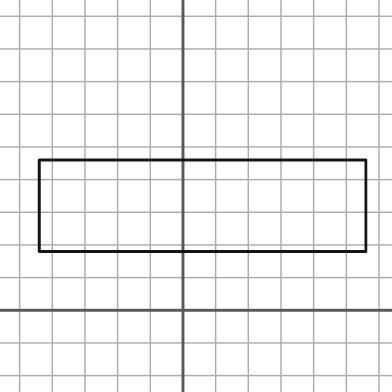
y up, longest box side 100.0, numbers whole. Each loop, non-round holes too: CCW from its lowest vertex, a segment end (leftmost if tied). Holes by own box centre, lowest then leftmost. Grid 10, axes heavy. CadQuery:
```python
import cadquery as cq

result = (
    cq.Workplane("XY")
    .moveTo(-44.0, 18.0)
    .lineTo(56.0, 18.0)
    .lineTo(56.0, 46.0)
    .lineTo(-44.0, 46.0)
    .close()
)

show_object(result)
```